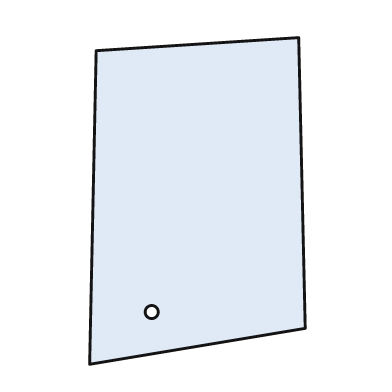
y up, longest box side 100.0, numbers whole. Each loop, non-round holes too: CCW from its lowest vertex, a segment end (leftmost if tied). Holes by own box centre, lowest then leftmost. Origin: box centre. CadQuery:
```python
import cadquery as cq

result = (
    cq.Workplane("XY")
    .moveTo(-33.0, -50.0)
    .lineTo(33.0, -39.0)
    .lineTo(31.0, 50.0)
    .lineTo(-31.0, 46.0)
    .close()
    .moveTo(-14.0, -34.0)
    .circle(2.0)
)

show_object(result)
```